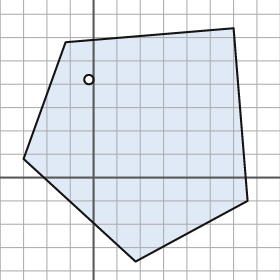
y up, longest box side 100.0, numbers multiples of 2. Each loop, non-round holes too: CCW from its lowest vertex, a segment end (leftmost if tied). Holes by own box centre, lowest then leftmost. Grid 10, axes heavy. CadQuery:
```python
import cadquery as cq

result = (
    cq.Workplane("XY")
    .moveTo(18.0, -36.0)
    .lineTo(66.0, -10.0)
    .lineTo(60.0, 64.0)
    .lineTo(-12.0, 58.0)
    .lineTo(-30.0, 8.0)
    .close()
    .moveTo(-2.0, 42.0)
    .circle(2.0)
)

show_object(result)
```